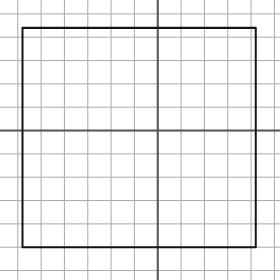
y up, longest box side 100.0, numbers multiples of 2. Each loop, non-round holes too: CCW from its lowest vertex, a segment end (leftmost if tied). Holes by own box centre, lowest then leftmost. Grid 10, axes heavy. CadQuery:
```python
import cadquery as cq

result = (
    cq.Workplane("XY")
    .moveTo(-58.0, -50.0)
    .lineTo(42.0, -50.0)
    .lineTo(42.0, 44.0)
    .lineTo(-58.0, 44.0)
    .close()
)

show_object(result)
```